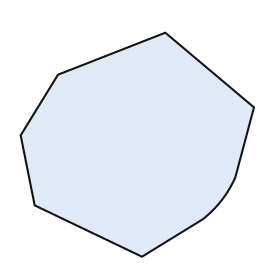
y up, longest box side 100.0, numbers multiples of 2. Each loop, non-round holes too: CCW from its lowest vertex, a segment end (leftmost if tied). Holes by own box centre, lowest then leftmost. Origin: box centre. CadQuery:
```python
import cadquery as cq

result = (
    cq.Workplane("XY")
    .moveTo(2.0, -48.0)
    .lineTo(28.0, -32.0)
    .threePointArc((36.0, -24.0), (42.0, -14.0))
    .lineTo(50.0, 16.0)
    .lineTo(12.0, 48.0)
    .lineTo(-34.0, 30.0)
    .lineTo(-50.0, 4.0)
    .lineTo(-44.0, -26.0)
    .close()
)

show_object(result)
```